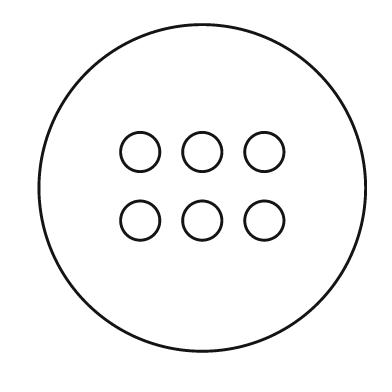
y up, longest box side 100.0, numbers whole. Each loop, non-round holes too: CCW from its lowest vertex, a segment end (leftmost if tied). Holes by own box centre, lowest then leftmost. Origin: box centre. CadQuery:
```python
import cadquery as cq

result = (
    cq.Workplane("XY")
    .moveTo(0.0, 0.0)
    .circle(50.0)
    .moveTo(-19.0, -10.0)
    .circle(6.0)
    .moveTo(0.0, -10.0)
    .circle(6.0)
    .moveTo(19.0, -10.0)
    .circle(6.0)
    .moveTo(-19.0, 11.0)
    .circle(6.0)
    .moveTo(0.0, 11.0)
    .circle(6.0)
    .moveTo(19.0, 11.0)
    .circle(6.0)
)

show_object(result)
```